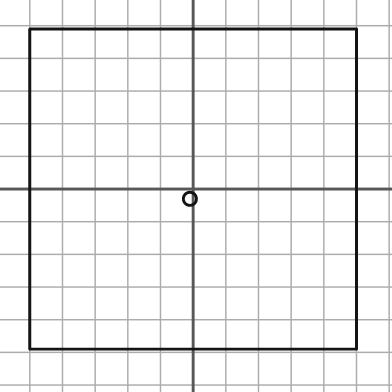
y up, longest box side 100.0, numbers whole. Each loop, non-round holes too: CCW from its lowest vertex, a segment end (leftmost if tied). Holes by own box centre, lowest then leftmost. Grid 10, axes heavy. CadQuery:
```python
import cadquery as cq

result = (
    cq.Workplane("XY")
    .moveTo(-50.0, -49.0)
    .lineTo(50.0, -49.0)
    .lineTo(50.0, 49.0)
    .lineTo(-50.0, 49.0)
    .close()
    .moveTo(-1.0, -3.0)
    .circle(2.0)
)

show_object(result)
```